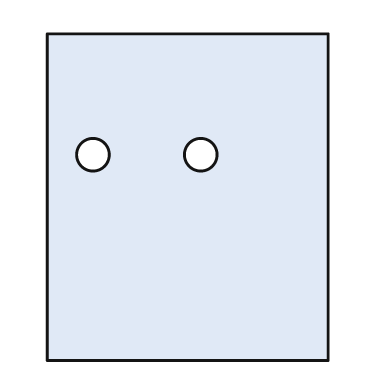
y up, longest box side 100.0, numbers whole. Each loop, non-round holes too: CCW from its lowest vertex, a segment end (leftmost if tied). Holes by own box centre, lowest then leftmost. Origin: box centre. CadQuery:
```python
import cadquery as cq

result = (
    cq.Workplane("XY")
    .moveTo(-43.0, -50.0)
    .lineTo(43.0, -50.0)
    .lineTo(43.0, 50.0)
    .lineTo(-43.0, 50.0)
    .close()
    .moveTo(-29.0, 13.0)
    .circle(5.0)
    .moveTo(4.0, 13.0)
    .circle(5.0)
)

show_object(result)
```